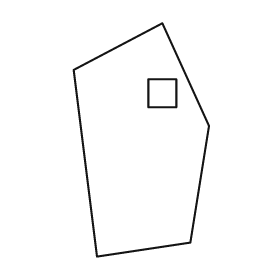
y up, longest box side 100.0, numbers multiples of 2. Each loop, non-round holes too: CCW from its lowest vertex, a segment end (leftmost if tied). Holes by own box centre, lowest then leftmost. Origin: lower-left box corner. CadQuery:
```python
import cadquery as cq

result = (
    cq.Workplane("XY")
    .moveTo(10.0, 0.0)
    .lineTo(50.0, 6.0)
    .lineTo(58.0, 56.0)
    .lineTo(38.0, 100.0)
    .lineTo(0.0, 80.0)
    .close()
    .moveTo(32.0, 64.0)
    .lineTo(44.0, 64.0)
    .lineTo(44.0, 76.0)
    .lineTo(32.0, 76.0)
    .close()
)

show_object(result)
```